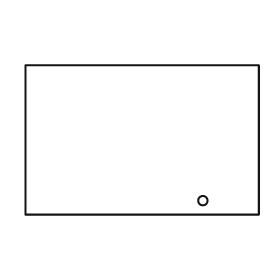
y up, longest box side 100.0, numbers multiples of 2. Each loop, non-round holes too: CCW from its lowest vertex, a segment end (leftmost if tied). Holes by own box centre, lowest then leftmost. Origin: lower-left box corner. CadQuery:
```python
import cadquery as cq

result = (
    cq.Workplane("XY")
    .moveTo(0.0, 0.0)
    .lineTo(100.0, 0.0)
    .lineTo(100.0, 64.0)
    .lineTo(0.0, 64.0)
    .close()
    .moveTo(76.0, 6.0)
    .circle(2.0)
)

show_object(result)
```